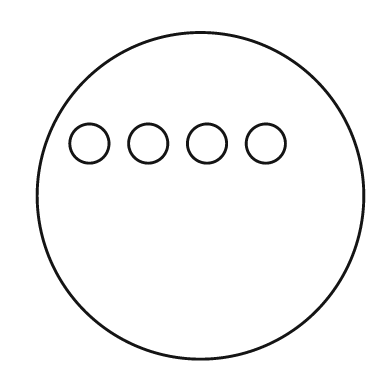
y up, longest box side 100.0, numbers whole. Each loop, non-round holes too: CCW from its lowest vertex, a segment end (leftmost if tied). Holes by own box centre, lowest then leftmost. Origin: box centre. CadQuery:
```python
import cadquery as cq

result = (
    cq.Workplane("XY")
    .moveTo(0.0, 0.0)
    .circle(50.0)
    .moveTo(-34.0, 16.0)
    .circle(6.0)
    .moveTo(-16.0, 16.0)
    .circle(6.0)
    .moveTo(2.0, 16.0)
    .circle(6.0)
    .moveTo(20.0, 16.0)
    .circle(6.0)
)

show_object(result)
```